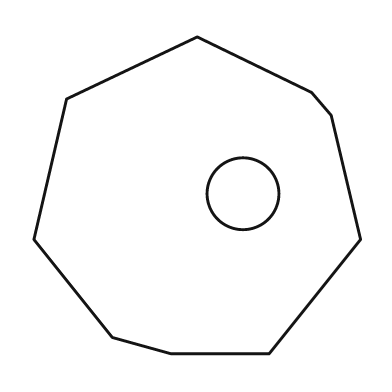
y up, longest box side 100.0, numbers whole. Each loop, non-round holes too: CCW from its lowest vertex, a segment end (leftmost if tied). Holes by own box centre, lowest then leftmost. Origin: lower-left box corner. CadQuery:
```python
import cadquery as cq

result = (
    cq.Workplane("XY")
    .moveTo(42.0, 0.0)
    .lineTo(72.0, 0.0)
    .lineTo(100.0, 35.0)
    .lineTo(91.0, 73.0)
    .lineTo(85.0, 80.0)
    .lineTo(50.0, 97.0)
    .lineTo(10.0, 78.0)
    .lineTo(0.0, 35.0)
    .lineTo(24.0, 5.0)
    .close()
    .moveTo(64.0, 49.0)
    .circle(11.0)
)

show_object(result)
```